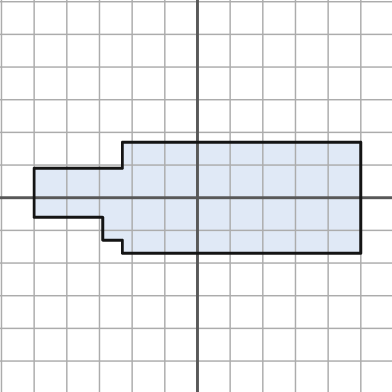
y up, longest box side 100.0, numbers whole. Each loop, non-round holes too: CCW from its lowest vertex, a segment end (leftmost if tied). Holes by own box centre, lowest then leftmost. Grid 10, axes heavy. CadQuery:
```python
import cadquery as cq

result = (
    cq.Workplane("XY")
    .moveTo(-23.0, -17.0)
    .lineTo(50.0, -17.0)
    .lineTo(50.0, 17.0)
    .lineTo(-23.0, 17.0)
    .lineTo(-23.0, 9.0)
    .lineTo(-50.0, 9.0)
    .lineTo(-50.0, -6.0)
    .lineTo(-29.0, -6.0)
    .lineTo(-29.0, -13.0)
    .lineTo(-23.0, -13.0)
    .close()
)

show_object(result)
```